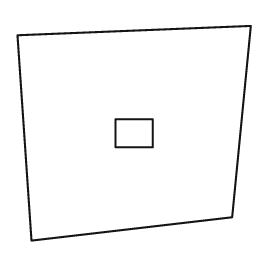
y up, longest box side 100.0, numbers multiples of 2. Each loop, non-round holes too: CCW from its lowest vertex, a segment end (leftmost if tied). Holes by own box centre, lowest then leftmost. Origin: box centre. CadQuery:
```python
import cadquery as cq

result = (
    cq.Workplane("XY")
    .moveTo(-44.0, -46.0)
    .lineTo(42.0, -36.0)
    .lineTo(50.0, 46.0)
    .lineTo(-50.0, 42.0)
    .close()
    .moveTo(-8.0, -6.0)
    .lineTo(8.0, -6.0)
    .lineTo(8.0, 6.0)
    .lineTo(-8.0, 6.0)
    .close()
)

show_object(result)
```